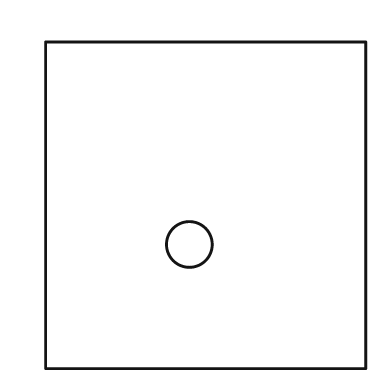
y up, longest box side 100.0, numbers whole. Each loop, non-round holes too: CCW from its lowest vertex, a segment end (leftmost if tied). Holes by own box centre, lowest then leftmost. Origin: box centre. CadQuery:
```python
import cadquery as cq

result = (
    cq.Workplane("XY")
    .moveTo(-49.0, -50.0)
    .lineTo(49.0, -50.0)
    .lineTo(49.0, 50.0)
    .lineTo(-49.0, 50.0)
    .close()
    .moveTo(-5.0, -12.0)
    .circle(7.0)
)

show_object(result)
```